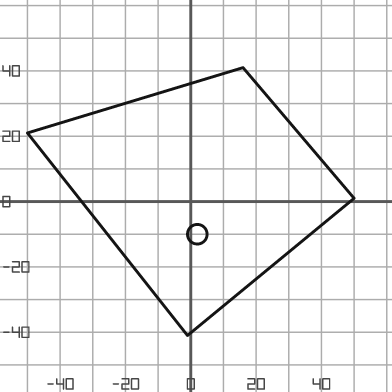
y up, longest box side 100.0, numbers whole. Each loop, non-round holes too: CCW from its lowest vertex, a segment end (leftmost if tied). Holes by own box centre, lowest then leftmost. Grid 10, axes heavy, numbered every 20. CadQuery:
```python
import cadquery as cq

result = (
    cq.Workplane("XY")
    .moveTo(-1.0, -41.0)
    .lineTo(50.0, 1.0)
    .lineTo(16.0, 41.0)
    .lineTo(-50.0, 21.0)
    .close()
    .moveTo(2.0, -10.0)
    .circle(3.0)
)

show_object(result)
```